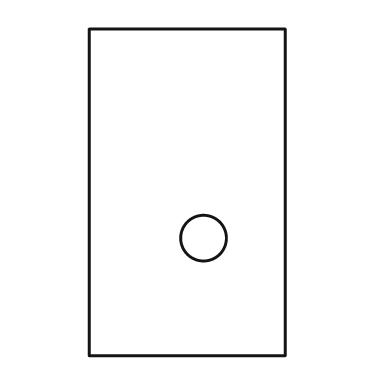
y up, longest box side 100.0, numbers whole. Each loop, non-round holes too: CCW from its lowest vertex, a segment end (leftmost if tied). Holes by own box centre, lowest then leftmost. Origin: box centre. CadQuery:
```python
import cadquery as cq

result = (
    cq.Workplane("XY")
    .moveTo(-30.0, -50.0)
    .lineTo(30.0, -50.0)
    .lineTo(30.0, 50.0)
    .lineTo(-30.0, 50.0)
    .close()
    .moveTo(5.0, -14.0)
    .circle(7.0)
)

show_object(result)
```